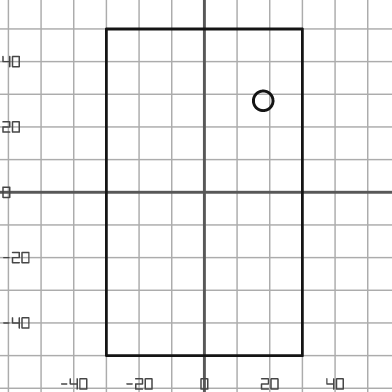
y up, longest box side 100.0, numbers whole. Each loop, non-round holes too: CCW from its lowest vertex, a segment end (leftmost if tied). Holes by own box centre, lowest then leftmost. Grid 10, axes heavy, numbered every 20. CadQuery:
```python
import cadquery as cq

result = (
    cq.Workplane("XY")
    .moveTo(-30.0, -50.0)
    .lineTo(30.0, -50.0)
    .lineTo(30.0, 50.0)
    .lineTo(-30.0, 50.0)
    .close()
    .moveTo(18.0, 28.0)
    .circle(3.0)
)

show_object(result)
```